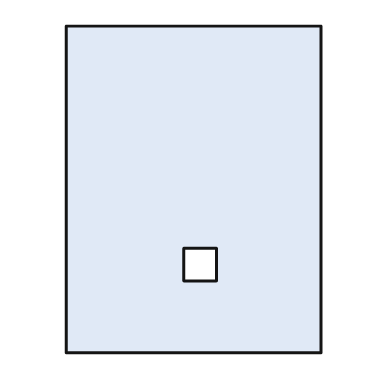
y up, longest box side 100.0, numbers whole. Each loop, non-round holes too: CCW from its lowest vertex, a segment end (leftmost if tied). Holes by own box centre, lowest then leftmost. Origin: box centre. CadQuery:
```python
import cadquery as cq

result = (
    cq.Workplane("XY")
    .moveTo(-39.0, -50.0)
    .lineTo(39.0, -50.0)
    .lineTo(39.0, 50.0)
    .lineTo(-39.0, 50.0)
    .close()
    .moveTo(-3.0, -28.0)
    .lineTo(7.0, -28.0)
    .lineTo(7.0, -18.0)
    .lineTo(-3.0, -18.0)
    .close()
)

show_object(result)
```